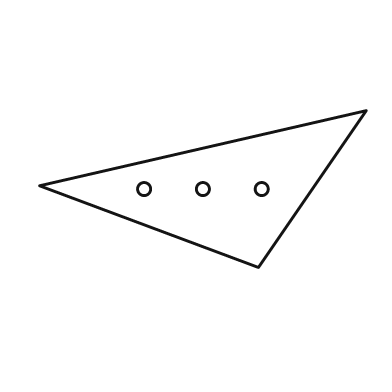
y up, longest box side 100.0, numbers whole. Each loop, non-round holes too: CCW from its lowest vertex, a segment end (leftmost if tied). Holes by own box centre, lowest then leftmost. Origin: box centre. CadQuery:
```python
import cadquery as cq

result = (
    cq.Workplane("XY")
    .moveTo(17.0, -24.0)
    .lineTo(50.0, 24.0)
    .lineTo(-50.0, 1.0)
    .close()
    .moveTo(-18.0, 0.0)
    .circle(2.0)
    .moveTo(0.0, 0.0)
    .circle(2.0)
    .moveTo(18.0, 0.0)
    .circle(2.0)
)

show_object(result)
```